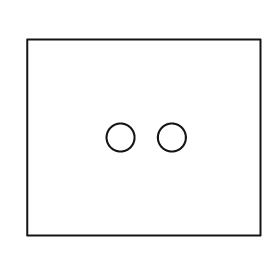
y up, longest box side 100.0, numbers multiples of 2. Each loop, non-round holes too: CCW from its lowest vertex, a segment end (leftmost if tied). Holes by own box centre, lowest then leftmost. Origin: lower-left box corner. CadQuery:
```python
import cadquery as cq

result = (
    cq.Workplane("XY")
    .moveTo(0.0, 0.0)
    .lineTo(100.0, 0.0)
    .lineTo(100.0, 84.0)
    .lineTo(0.0, 84.0)
    .close()
    .moveTo(40.0, 42.0)
    .circle(6.0)
    .moveTo(62.0, 42.0)
    .circle(6.0)
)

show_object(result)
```